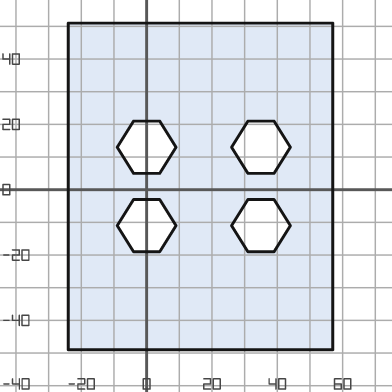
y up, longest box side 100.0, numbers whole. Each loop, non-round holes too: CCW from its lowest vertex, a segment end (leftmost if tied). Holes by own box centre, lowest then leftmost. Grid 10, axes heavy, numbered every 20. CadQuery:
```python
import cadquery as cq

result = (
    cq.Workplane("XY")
    .moveTo(-24.0, -49.0)
    .lineTo(57.0, -49.0)
    .lineTo(57.0, 51.0)
    .lineTo(-24.0, 51.0)
    .close()
    .moveTo(-4.0, -19.0)
    .lineTo(4.0, -19.0)
    .lineTo(9.0, -11.0)
    .lineTo(4.0, -3.0)
    .lineTo(-4.0, -3.0)
    .lineTo(-9.0, -11.0)
    .close()
    .moveTo(31.0, -19.0)
    .lineTo(39.0, -19.0)
    .lineTo(44.0, -11.0)
    .lineTo(39.0, -3.0)
    .lineTo(31.0, -3.0)
    .lineTo(26.0, -11.0)
    .close()
    .moveTo(-4.0, 5.0)
    .lineTo(4.0, 5.0)
    .lineTo(9.0, 13.0)
    .lineTo(4.0, 21.0)
    .lineTo(-4.0, 21.0)
    .lineTo(-9.0, 13.0)
    .close()
    .moveTo(31.0, 5.0)
    .lineTo(39.0, 5.0)
    .lineTo(44.0, 13.0)
    .lineTo(39.0, 21.0)
    .lineTo(31.0, 21.0)
    .lineTo(26.0, 13.0)
    .close()
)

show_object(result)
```